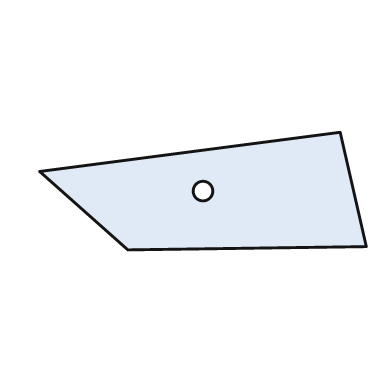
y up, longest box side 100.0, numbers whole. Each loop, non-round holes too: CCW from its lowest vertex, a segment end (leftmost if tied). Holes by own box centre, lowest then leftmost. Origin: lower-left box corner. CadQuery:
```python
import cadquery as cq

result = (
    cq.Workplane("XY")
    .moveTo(27.0, 0.0)
    .lineTo(100.0, 1.0)
    .lineTo(92.0, 36.0)
    .lineTo(0.0, 24.0)
    .close()
    .moveTo(50.0, 18.0)
    .circle(3.0)
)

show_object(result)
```